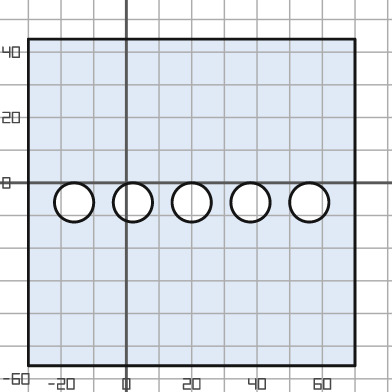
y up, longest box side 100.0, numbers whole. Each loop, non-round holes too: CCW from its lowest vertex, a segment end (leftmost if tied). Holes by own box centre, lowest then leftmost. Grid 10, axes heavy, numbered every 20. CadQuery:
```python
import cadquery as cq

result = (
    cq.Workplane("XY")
    .moveTo(-30.0, -56.0)
    .lineTo(70.0, -56.0)
    .lineTo(70.0, 44.0)
    .lineTo(-30.0, 44.0)
    .close()
    .moveTo(-16.0, -6.0)
    .circle(6.0)
    .moveTo(2.0, -6.0)
    .circle(6.0)
    .moveTo(20.0, -6.0)
    .circle(6.0)
    .moveTo(38.0, -6.0)
    .circle(6.0)
    .moveTo(56.0, -6.0)
    .circle(6.0)
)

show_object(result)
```